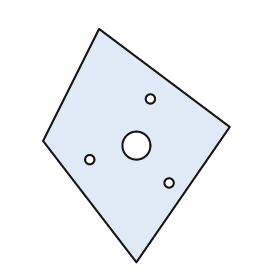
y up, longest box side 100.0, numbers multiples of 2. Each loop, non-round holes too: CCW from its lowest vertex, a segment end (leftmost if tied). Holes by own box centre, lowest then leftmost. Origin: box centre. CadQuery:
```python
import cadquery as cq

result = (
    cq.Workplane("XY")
    .moveTo(0.0, -50.0)
    .lineTo(40.0, 8.0)
    .lineTo(-16.0, 50.0)
    .lineTo(-40.0, 2.0)
    .close()
    .moveTo(14.0, -16.0)
    .circle(2.0)
    .moveTo(-20.0, -6.0)
    .circle(2.0)
    .moveTo(0.0, 0.0)
    .circle(6.0)
    .moveTo(6.0, 20.0)
    .circle(2.0)
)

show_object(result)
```